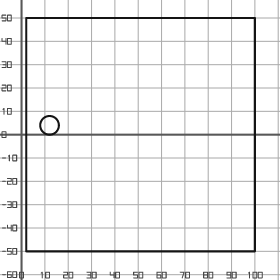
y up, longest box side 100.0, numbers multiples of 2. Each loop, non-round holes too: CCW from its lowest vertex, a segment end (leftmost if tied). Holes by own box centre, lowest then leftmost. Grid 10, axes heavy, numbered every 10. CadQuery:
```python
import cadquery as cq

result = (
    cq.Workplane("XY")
    .moveTo(2.0, -50.0)
    .lineTo(100.0, -50.0)
    .lineTo(100.0, 50.0)
    .lineTo(2.0, 50.0)
    .close()
    .moveTo(12.0, 4.0)
    .circle(4.0)
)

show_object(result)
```